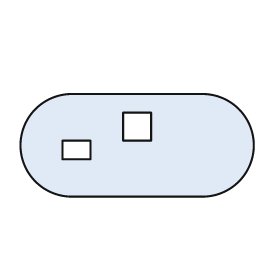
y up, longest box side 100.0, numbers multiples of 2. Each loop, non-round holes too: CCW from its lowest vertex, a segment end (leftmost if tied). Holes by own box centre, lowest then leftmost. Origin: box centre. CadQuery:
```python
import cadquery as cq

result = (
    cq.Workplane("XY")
    .moveTo(-28.0, -22.0)
    .lineTo(28.0, -22.0)
    .threePointArc((50.0, 0.0), (28.0, 22.0))
    .lineTo(-28.0, 22.0)
    .threePointArc((-50.0, 0.0), (-28.0, -22.0))
    .close()
    .moveTo(-32.0, -6.0)
    .lineTo(-20.0, -6.0)
    .lineTo(-20.0, 2.0)
    .lineTo(-32.0, 2.0)
    .close()
    .moveTo(-6.0, 2.0)
    .lineTo(6.0, 2.0)
    .lineTo(6.0, 14.0)
    .lineTo(-6.0, 14.0)
    .close()
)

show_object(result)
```